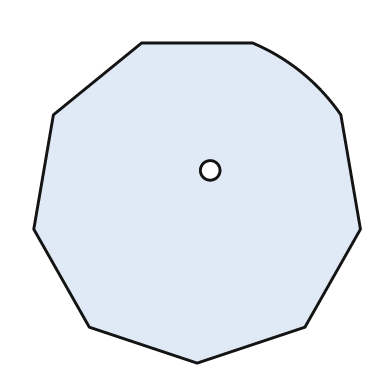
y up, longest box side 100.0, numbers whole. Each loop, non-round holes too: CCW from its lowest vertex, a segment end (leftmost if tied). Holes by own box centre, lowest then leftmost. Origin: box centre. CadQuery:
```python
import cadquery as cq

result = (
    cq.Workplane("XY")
    .moveTo(0.0, -49.0)
    .lineTo(33.0, -38.0)
    .lineTo(50.0, -8.0)
    .lineTo(44.0, 27.0)
    .threePointArc((32.0, 40.0), (17.0, 49.0))
    .lineTo(-17.0, 49.0)
    .lineTo(-44.0, 27.0)
    .lineTo(-50.0, -8.0)
    .lineTo(-33.0, -38.0)
    .close()
    .moveTo(4.0, 10.0)
    .circle(3.0)
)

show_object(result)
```